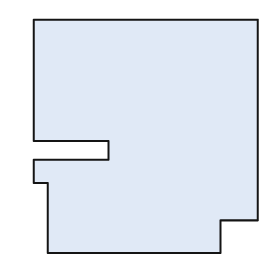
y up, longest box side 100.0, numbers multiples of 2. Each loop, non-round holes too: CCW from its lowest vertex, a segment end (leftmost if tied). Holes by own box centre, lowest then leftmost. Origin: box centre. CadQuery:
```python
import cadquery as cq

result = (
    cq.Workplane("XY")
    .moveTo(-42.0, -50.0)
    .lineTo(32.0, -50.0)
    .lineTo(32.0, -36.0)
    .lineTo(48.0, -36.0)
    .lineTo(48.0, 50.0)
    .lineTo(-48.0, 50.0)
    .lineTo(-48.0, -2.0)
    .lineTo(-16.0, -2.0)
    .lineTo(-16.0, -10.0)
    .lineTo(-48.0, -10.0)
    .lineTo(-48.0, -20.0)
    .lineTo(-42.0, -20.0)
    .close()
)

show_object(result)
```